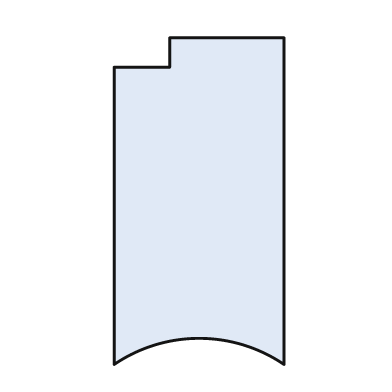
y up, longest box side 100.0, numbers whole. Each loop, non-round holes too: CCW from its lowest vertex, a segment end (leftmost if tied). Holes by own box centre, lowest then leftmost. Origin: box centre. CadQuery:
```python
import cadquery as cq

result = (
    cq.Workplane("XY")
    .moveTo(-26.0, -50.0)
    .threePointArc((0.0, -42.0), (26.0, -50.0))
    .lineTo(26.0, 50.0)
    .lineTo(-9.0, 50.0)
    .lineTo(-9.0, 41.0)
    .lineTo(-26.0, 41.0)
    .close()
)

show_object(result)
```